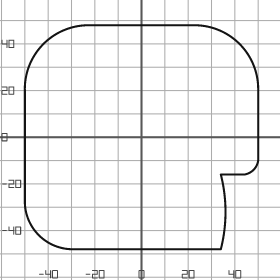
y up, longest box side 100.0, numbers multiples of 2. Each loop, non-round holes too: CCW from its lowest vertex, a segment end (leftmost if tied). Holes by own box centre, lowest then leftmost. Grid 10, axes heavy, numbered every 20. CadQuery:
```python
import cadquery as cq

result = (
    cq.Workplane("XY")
    .moveTo(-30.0, -48.0)
    .lineTo(34.0, -48.0)
    .threePointArc((36.0, -32.0), (34.0, -16.0))
    .lineTo(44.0, -16.0)
    .threePointArc((48.0, -14.0), (50.0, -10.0))
    .lineTo(50.0, 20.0)
    .threePointArc((42.0, 40.0), (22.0, 48.0))
    .lineTo(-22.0, 48.0)
    .threePointArc((-42.0, 40.0), (-50.0, 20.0))
    .lineTo(-50.0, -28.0)
    .threePointArc((-44.0, -42.0), (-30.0, -48.0))
    .close()
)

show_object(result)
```